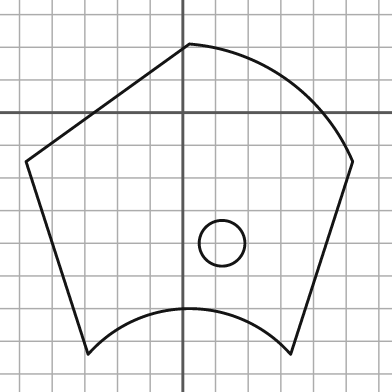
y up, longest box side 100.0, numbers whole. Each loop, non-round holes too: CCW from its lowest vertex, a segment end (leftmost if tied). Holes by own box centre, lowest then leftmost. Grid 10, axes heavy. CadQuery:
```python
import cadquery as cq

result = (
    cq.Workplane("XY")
    .moveTo(-29.0, -74.0)
    .threePointArc((2.0, -60.0), (33.0, -74.0))
    .lineTo(52.0, -15.0)
    .threePointArc((32.0, 10.0), (2.0, 21.0))
    .lineTo(-48.0, -15.0)
    .close()
    .moveTo(12.0, -40.0)
    .circle(7.0)
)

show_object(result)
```